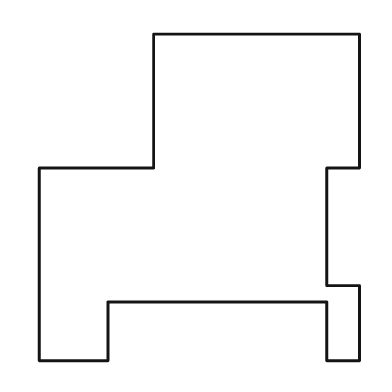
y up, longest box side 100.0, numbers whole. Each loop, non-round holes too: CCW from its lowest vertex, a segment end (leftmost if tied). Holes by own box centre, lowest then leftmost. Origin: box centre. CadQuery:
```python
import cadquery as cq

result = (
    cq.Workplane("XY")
    .moveTo(-49.0, -50.0)
    .lineTo(-28.0, -50.0)
    .lineTo(-28.0, -32.0)
    .lineTo(39.0, -32.0)
    .lineTo(39.0, -50.0)
    .lineTo(49.0, -50.0)
    .lineTo(49.0, -27.0)
    .lineTo(39.0, -27.0)
    .lineTo(39.0, 9.0)
    .lineTo(49.0, 9.0)
    .lineTo(49.0, 50.0)
    .lineTo(-14.0, 50.0)
    .lineTo(-14.0, 9.0)
    .lineTo(-49.0, 9.0)
    .close()
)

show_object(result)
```